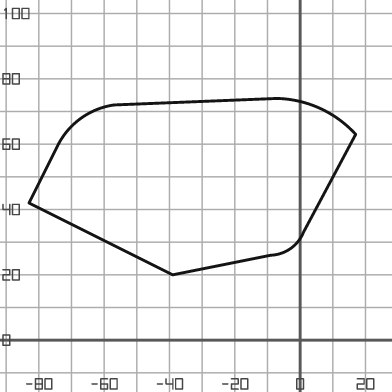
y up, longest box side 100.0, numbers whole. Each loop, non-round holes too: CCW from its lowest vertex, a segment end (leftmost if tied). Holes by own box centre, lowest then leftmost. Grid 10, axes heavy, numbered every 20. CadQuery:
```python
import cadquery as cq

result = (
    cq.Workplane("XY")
    .moveTo(-39.0, 20.0)
    .lineTo(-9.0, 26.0)
    .threePointArc((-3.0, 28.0), (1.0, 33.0))
    .lineTo(17.0, 63.0)
    .threePointArc((6.0, 71.0), (-7.0, 74.0))
    .lineTo(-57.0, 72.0)
    .threePointArc((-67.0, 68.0), (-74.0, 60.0))
    .lineTo(-83.0, 42.0)
    .close()
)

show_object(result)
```